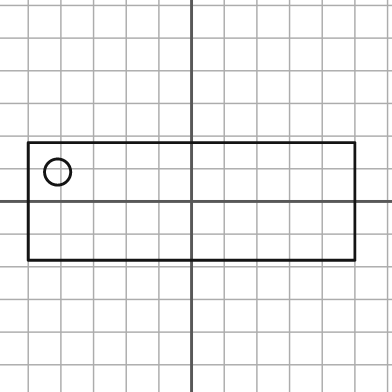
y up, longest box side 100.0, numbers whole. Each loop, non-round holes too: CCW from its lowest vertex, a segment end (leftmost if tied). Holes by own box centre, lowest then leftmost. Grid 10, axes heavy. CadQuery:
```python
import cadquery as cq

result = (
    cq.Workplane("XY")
    .moveTo(-50.0, -18.0)
    .lineTo(50.0, -18.0)
    .lineTo(50.0, 18.0)
    .lineTo(-50.0, 18.0)
    .close()
    .moveTo(-41.0, 9.0)
    .circle(4.0)
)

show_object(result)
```